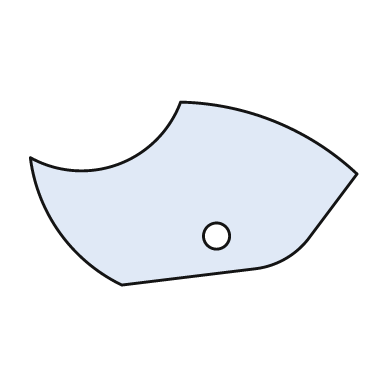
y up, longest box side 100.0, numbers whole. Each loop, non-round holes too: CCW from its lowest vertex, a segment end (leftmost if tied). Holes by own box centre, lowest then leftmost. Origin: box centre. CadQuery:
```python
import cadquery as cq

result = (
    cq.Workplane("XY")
    .moveTo(-22.0, -28.0)
    .lineTo(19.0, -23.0)
    .threePointArc((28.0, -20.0), (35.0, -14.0))
    .lineTo(50.0, 6.0)
    .threePointArc((25.0, 22.0), (-4.0, 28.0))
    .threePointArc((-23.0, 9.0), (-50.0, 11.0))
    .threePointArc((-41.0, -12.0), (-22.0, -28.0))
    .close()
    .moveTo(7.0, -13.0)
    .circle(4.0)
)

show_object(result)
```